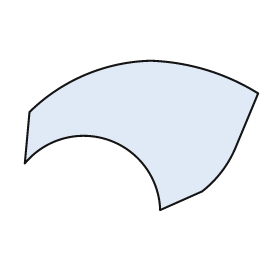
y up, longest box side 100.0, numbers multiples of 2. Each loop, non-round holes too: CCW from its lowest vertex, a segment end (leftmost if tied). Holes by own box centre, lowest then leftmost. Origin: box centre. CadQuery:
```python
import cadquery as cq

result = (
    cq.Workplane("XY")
    .moveTo(8.0, -32.0)
    .lineTo(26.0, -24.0)
    .threePointArc((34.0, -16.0), (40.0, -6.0))
    .lineTo(50.0, 18.0)
    .threePointArc((28.0, 28.0), (4.0, 32.0))
    .threePointArc((-24.0, 26.0), (-48.0, 10.0))
    .lineTo(-50.0, -12.0)
    .threePointArc((-14.0, -2.0), (8.0, -32.0))
    .close()
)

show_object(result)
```